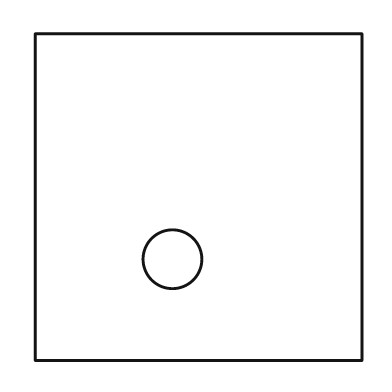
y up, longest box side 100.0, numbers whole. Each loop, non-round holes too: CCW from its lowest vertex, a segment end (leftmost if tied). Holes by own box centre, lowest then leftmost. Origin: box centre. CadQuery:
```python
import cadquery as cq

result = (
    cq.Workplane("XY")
    .moveTo(-50.0, -50.0)
    .lineTo(50.0, -50.0)
    .lineTo(50.0, 50.0)
    .lineTo(-50.0, 50.0)
    .close()
    .moveTo(-8.0, -19.0)
    .circle(9.0)
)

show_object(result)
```